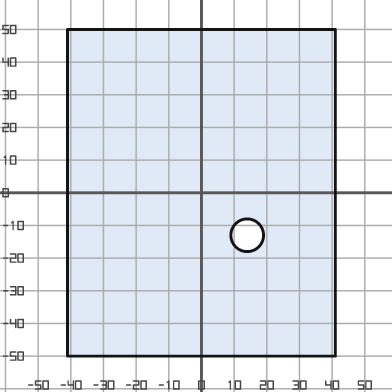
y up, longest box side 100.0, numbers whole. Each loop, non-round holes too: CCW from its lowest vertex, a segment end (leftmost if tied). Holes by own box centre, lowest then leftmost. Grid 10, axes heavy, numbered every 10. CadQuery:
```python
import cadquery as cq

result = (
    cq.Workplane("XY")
    .moveTo(-41.0, -50.0)
    .lineTo(41.0, -50.0)
    .lineTo(41.0, 50.0)
    .lineTo(-41.0, 50.0)
    .close()
    .moveTo(14.0, -13.0)
    .circle(5.0)
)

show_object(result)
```